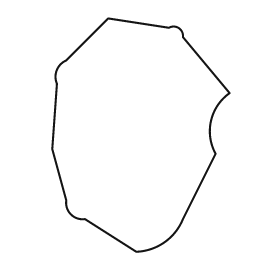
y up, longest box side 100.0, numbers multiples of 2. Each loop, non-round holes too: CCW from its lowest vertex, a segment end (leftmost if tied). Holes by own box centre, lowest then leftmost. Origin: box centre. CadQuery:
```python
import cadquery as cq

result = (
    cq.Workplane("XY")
    .moveTo(-2.0, -50.0)
    .threePointArc((10.0, -46.0), (18.0, -36.0))
    .lineTo(32.0, -8.0)
    .threePointArc((30.0, 6.0), (38.0, 18.0))
    .lineTo(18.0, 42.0)
    .threePointArc((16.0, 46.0), (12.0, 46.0))
    .lineTo(-14.0, 50.0)
    .lineTo(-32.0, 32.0)
    .threePointArc((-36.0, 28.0), (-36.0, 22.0))
    .lineTo(-38.0, -6.0)
    .lineTo(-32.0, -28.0)
    .threePointArc((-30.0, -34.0), (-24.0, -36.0))
    .close()
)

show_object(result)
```